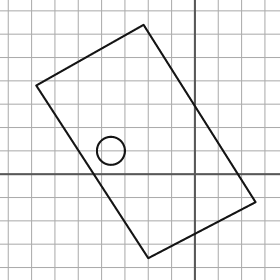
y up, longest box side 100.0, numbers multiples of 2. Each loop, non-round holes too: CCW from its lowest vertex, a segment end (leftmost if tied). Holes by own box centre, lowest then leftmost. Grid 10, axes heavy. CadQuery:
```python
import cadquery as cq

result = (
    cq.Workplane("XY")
    .moveTo(-20.0, -36.0)
    .lineTo(26.0, -12.0)
    .lineTo(-22.0, 64.0)
    .lineTo(-68.0, 38.0)
    .close()
    .moveTo(-36.0, 10.0)
    .circle(6.0)
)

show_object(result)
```